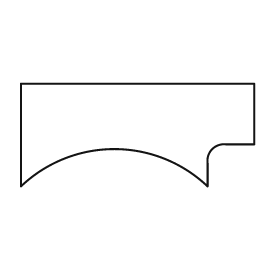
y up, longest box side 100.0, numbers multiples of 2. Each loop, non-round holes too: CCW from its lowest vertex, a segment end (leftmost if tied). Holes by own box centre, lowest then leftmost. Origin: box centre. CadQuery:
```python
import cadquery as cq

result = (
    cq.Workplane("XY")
    .moveTo(-50.0, -22.0)
    .threePointArc((-10.0, -6.0), (30.0, -22.0))
    .lineTo(30.0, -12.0)
    .threePointArc((32.0, -6.0), (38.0, -4.0))
    .lineTo(50.0, -4.0)
    .lineTo(50.0, 22.0)
    .lineTo(-50.0, 22.0)
    .close()
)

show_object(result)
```